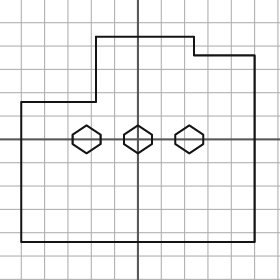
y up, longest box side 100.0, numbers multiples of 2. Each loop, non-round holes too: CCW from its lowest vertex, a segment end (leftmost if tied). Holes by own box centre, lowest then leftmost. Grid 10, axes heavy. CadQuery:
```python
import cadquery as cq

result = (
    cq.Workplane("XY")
    .moveTo(-50.0, -44.0)
    .lineTo(50.0, -44.0)
    .lineTo(50.0, 36.0)
    .lineTo(24.0, 36.0)
    .lineTo(24.0, 44.0)
    .lineTo(-18.0, 44.0)
    .lineTo(-18.0, 16.0)
    .lineTo(-50.0, 16.0)
    .close()
    .moveTo(-22.0, -6.0)
    .lineTo(-16.0, -2.0)
    .lineTo(-16.0, 2.0)
    .lineTo(-22.0, 6.0)
    .lineTo(-28.0, 2.0)
    .lineTo(-28.0, -2.0)
    .close()
    .moveTo(0.0, -6.0)
    .lineTo(6.0, -2.0)
    .lineTo(6.0, 2.0)
    .lineTo(0.0, 6.0)
    .lineTo(-6.0, 2.0)
    .lineTo(-6.0, -2.0)
    .close()
    .moveTo(22.0, -6.0)
    .lineTo(28.0, -2.0)
    .lineTo(28.0, 2.0)
    .lineTo(22.0, 6.0)
    .lineTo(16.0, 2.0)
    .lineTo(16.0, -2.0)
    .close()
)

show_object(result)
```